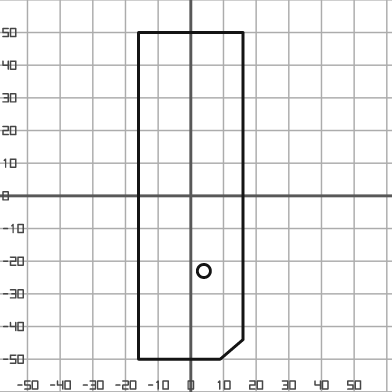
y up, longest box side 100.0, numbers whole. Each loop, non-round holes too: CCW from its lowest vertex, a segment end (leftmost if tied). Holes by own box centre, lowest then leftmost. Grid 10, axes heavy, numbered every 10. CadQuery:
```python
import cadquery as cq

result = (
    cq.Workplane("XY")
    .moveTo(-16.0, -50.0)
    .lineTo(9.0, -50.0)
    .lineTo(16.0, -44.0)
    .lineTo(16.0, 50.0)
    .lineTo(-16.0, 50.0)
    .close()
    .moveTo(4.0, -23.0)
    .circle(2.0)
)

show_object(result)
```